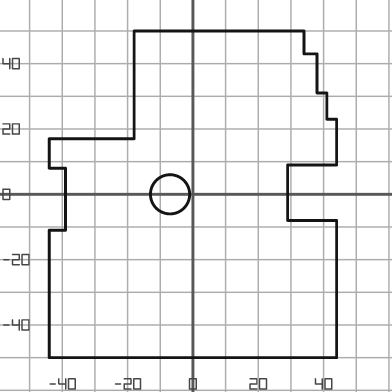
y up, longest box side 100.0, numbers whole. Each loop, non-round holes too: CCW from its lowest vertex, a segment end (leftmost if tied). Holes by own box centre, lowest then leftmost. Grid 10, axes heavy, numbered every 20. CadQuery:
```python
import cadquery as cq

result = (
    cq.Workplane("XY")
    .moveTo(-44.0, -50.0)
    .lineTo(44.0, -50.0)
    .lineTo(44.0, -8.0)
    .lineTo(29.0, -8.0)
    .lineTo(29.0, 9.0)
    .lineTo(44.0, 9.0)
    .lineTo(44.0, 23.0)
    .lineTo(41.0, 23.0)
    .lineTo(41.0, 31.0)
    .lineTo(38.0, 31.0)
    .lineTo(38.0, 43.0)
    .lineTo(34.0, 43.0)
    .lineTo(34.0, 50.0)
    .lineTo(-18.0, 50.0)
    .lineTo(-18.0, 17.0)
    .lineTo(-44.0, 17.0)
    .lineTo(-44.0, 8.0)
    .lineTo(-39.0, 8.0)
    .lineTo(-39.0, -11.0)
    .lineTo(-44.0, -11.0)
    .close()
    .moveTo(-7.0, 0.0)
    .circle(6.0)
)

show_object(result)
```